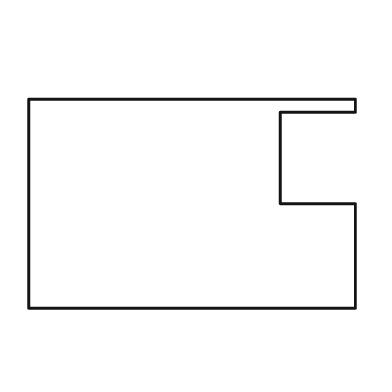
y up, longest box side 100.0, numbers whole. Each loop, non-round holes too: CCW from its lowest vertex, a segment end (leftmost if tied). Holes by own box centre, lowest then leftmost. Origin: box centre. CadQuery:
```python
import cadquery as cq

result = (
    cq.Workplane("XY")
    .moveTo(-50.0, -32.0)
    .lineTo(50.0, -32.0)
    .lineTo(50.0, 0.0)
    .lineTo(27.0, 0.0)
    .lineTo(27.0, 28.0)
    .lineTo(50.0, 28.0)
    .lineTo(50.0, 32.0)
    .lineTo(-50.0, 32.0)
    .close()
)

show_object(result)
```